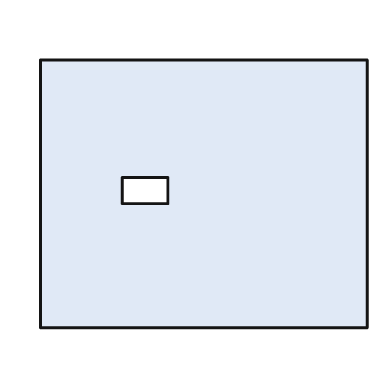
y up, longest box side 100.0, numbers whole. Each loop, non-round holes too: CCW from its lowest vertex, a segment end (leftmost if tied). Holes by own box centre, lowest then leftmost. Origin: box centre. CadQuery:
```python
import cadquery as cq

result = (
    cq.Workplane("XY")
    .moveTo(-50.0, -41.0)
    .lineTo(50.0, -41.0)
    .lineTo(50.0, 41.0)
    .lineTo(-50.0, 41.0)
    .close()
    .moveTo(-25.0, -3.0)
    .lineTo(-11.0, -3.0)
    .lineTo(-11.0, 5.0)
    .lineTo(-25.0, 5.0)
    .close()
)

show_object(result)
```